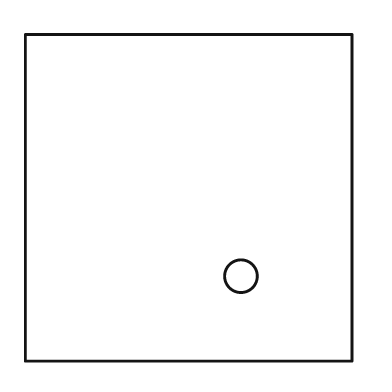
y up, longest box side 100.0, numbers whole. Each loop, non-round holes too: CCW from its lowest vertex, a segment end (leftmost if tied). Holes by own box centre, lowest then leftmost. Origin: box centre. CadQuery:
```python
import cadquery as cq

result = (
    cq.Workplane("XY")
    .moveTo(-50.0, -50.0)
    .lineTo(50.0, -50.0)
    .lineTo(50.0, 50.0)
    .lineTo(-50.0, 50.0)
    .close()
    .moveTo(16.0, -24.0)
    .circle(5.0)
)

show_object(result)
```